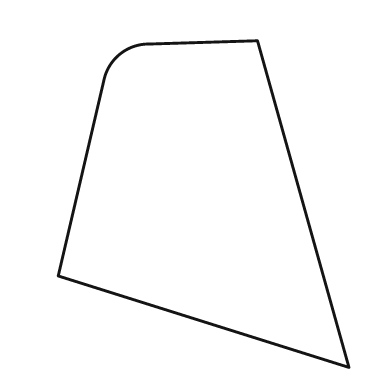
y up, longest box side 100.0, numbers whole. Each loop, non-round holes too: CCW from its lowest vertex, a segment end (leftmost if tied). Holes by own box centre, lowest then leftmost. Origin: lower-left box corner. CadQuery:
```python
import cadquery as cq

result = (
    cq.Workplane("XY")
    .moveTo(89.0, 0.0)
    .lineTo(61.0, 100.0)
    .lineTo(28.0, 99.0)
    .threePointArc((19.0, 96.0), (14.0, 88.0))
    .lineTo(0.0, 28.0)
    .close()
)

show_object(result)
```